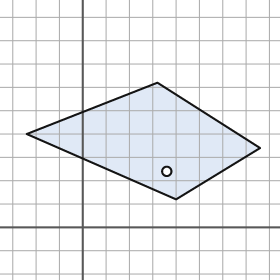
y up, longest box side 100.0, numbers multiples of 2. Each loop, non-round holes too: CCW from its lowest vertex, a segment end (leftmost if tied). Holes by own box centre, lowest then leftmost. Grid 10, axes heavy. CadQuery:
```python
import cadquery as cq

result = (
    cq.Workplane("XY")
    .moveTo(40.0, 12.0)
    .lineTo(76.0, 34.0)
    .lineTo(32.0, 62.0)
    .lineTo(-24.0, 40.0)
    .close()
    .moveTo(36.0, 24.0)
    .circle(2.0)
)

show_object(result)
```